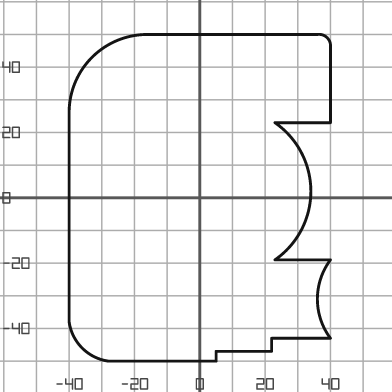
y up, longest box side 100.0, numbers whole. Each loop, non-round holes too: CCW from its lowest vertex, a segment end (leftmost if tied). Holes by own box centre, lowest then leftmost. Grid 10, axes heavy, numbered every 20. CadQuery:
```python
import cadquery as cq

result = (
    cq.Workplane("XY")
    .moveTo(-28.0, -50.0)
    .lineTo(5.0, -50.0)
    .lineTo(5.0, -47.0)
    .lineTo(22.0, -47.0)
    .lineTo(22.0, -43.0)
    .lineTo(40.0, -43.0)
    .threePointArc((36.0, -31.0), (40.0, -19.0))
    .lineTo(23.0, -19.0)
    .threePointArc((34.0, 2.0), (23.0, 23.0))
    .lineTo(40.0, 23.0)
    .lineTo(40.0, 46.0)
    .threePointArc((39.0, 49.0), (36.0, 50.0))
    .lineTo(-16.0, 50.0)
    .threePointArc((-33.0, 43.0), (-40.0, 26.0))
    .lineTo(-40.0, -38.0)
    .threePointArc((-36.0, -46.0), (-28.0, -50.0))
    .close()
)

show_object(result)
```